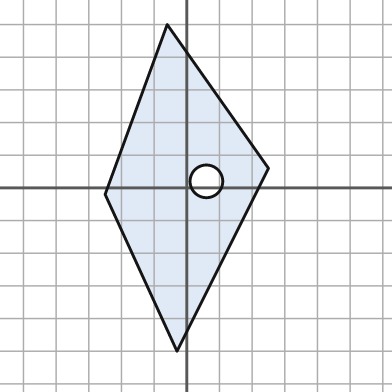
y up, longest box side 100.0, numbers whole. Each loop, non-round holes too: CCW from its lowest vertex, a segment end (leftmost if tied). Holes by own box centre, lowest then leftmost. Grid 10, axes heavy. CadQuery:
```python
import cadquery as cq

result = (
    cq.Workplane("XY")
    .moveTo(-3.0, -50.0)
    .lineTo(25.0, 6.0)
    .lineTo(-6.0, 50.0)
    .lineTo(-25.0, -2.0)
    .close()
    .moveTo(6.0, 2.0)
    .circle(5.0)
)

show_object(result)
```